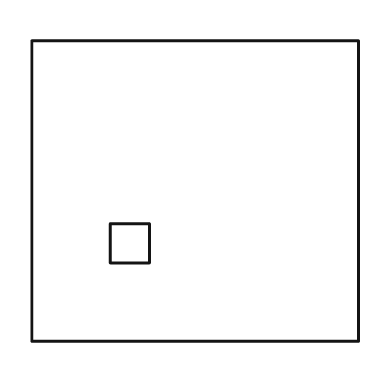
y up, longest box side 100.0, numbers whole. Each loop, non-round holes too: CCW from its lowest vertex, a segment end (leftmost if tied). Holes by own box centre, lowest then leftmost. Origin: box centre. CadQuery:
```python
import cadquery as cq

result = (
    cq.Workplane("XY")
    .moveTo(-50.0, -46.0)
    .lineTo(50.0, -46.0)
    .lineTo(50.0, 46.0)
    .lineTo(-50.0, 46.0)
    .close()
    .moveTo(-26.0, -22.0)
    .lineTo(-14.0, -22.0)
    .lineTo(-14.0, -10.0)
    .lineTo(-26.0, -10.0)
    .close()
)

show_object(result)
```